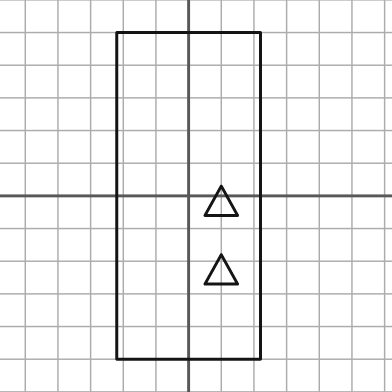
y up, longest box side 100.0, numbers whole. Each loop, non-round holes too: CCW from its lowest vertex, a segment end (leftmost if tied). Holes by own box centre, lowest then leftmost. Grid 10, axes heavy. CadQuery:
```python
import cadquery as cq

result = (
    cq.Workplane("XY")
    .moveTo(-22.0, -50.0)
    .lineTo(22.0, -50.0)
    .lineTo(22.0, 50.0)
    .lineTo(-22.0, 50.0)
    .close()
    .moveTo(5.0, -27.0)
    .lineTo(15.0, -27.0)
    .lineTo(10.0, -18.0)
    .close()
    .moveTo(5.0, -6.0)
    .lineTo(15.0, -6.0)
    .lineTo(10.0, 3.0)
    .close()
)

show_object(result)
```